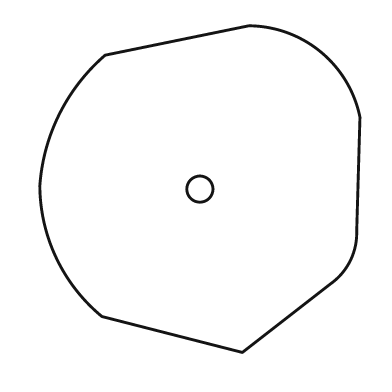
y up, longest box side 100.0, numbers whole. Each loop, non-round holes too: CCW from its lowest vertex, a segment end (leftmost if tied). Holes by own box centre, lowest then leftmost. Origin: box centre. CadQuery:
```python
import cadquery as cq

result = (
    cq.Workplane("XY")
    .moveTo(13.0, -50.0)
    .lineTo(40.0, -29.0)
    .threePointArc((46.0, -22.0), (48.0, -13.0))
    .lineTo(49.0, 22.0)
    .threePointArc((37.0, 42.0), (15.0, 50.0))
    .lineTo(-29.0, 41.0)
    .threePointArc((-43.0, 23.0), (-49.0, 1.0))
    .threePointArc((-44.0, -21.0), (-30.0, -39.0))
    .close()
    .moveTo(0.0, 0.0)
    .circle(4.0)
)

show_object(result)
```